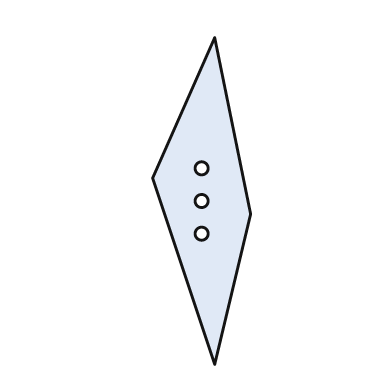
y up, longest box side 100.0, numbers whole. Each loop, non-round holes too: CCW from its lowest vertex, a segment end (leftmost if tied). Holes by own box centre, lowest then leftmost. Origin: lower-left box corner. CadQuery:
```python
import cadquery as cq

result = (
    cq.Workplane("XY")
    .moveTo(19.0, 0.0)
    .lineTo(30.0, 46.0)
    .lineTo(19.0, 100.0)
    .lineTo(0.0, 57.0)
    .close()
    .moveTo(15.0, 40.0)
    .circle(2.0)
    .moveTo(15.0, 50.0)
    .circle(2.0)
    .moveTo(15.0, 60.0)
    .circle(2.0)
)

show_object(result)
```